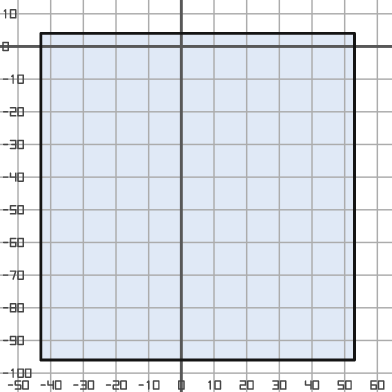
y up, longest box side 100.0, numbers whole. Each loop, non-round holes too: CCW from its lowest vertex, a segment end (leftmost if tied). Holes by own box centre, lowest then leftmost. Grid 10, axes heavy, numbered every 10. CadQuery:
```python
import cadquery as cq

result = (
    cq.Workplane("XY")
    .moveTo(-43.0, -96.0)
    .lineTo(53.0, -96.0)
    .lineTo(53.0, 4.0)
    .lineTo(-43.0, 4.0)
    .close()
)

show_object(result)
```